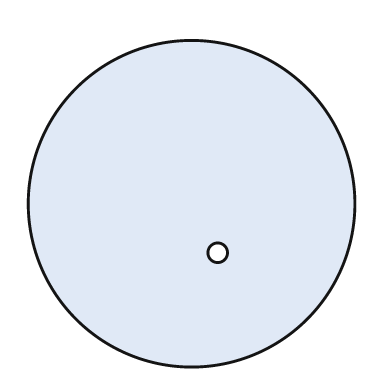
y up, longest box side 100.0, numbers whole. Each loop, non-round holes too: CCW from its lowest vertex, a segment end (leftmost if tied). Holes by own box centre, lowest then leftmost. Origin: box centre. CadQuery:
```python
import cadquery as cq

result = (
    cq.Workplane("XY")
    .moveTo(0.0, 0.0)
    .circle(50.0)
    .moveTo(8.0, -15.0)
    .circle(3.0)
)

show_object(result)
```